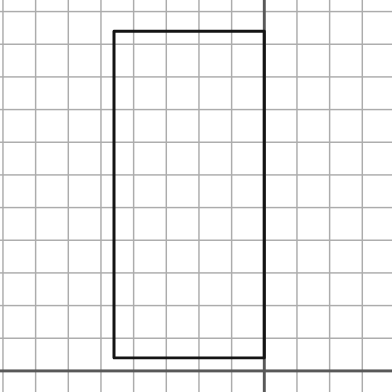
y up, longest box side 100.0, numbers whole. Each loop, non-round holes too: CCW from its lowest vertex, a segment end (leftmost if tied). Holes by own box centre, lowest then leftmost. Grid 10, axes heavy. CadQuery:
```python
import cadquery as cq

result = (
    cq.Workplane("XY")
    .moveTo(-46.0, 4.0)
    .lineTo(0.0, 4.0)
    .lineTo(0.0, 104.0)
    .lineTo(-46.0, 104.0)
    .close()
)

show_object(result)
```